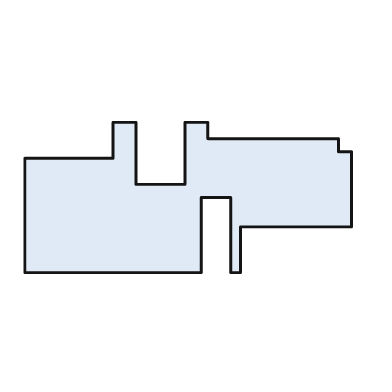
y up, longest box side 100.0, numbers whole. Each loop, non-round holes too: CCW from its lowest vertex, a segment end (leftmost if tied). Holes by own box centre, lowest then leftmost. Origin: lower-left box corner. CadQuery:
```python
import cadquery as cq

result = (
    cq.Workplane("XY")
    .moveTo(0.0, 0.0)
    .lineTo(54.0, 0.0)
    .lineTo(54.0, 23.0)
    .lineTo(63.0, 23.0)
    .lineTo(63.0, 0.0)
    .lineTo(66.0, 0.0)
    .lineTo(66.0, 14.0)
    .lineTo(100.0, 14.0)
    .lineTo(100.0, 37.0)
    .lineTo(96.0, 37.0)
    .lineTo(96.0, 41.0)
    .lineTo(56.0, 41.0)
    .lineTo(56.0, 46.0)
    .lineTo(49.0, 46.0)
    .lineTo(49.0, 27.0)
    .lineTo(34.0, 27.0)
    .lineTo(34.0, 46.0)
    .lineTo(27.0, 46.0)
    .lineTo(27.0, 35.0)
    .lineTo(0.0, 35.0)
    .close()
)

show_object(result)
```